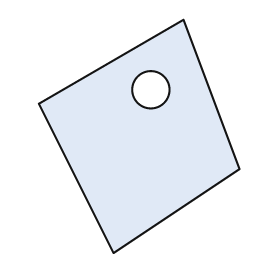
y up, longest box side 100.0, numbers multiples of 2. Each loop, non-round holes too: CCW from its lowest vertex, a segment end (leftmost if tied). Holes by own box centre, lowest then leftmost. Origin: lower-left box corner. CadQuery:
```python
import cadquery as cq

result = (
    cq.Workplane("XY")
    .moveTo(32.0, 0.0)
    .lineTo(86.0, 36.0)
    .lineTo(62.0, 100.0)
    .lineTo(0.0, 64.0)
    .close()
    .moveTo(48.0, 70.0)
    .circle(8.0)
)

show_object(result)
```